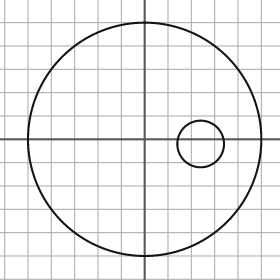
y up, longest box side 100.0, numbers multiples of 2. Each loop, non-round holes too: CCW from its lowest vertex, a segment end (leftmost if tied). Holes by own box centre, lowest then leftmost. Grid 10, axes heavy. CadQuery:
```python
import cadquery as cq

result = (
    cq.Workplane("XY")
    .moveTo(0.0, 0.0)
    .circle(50.0)
    .moveTo(24.0, -2.0)
    .circle(10.0)
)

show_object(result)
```